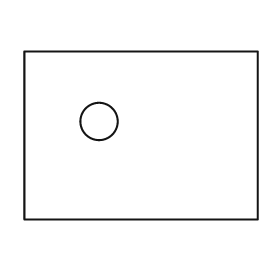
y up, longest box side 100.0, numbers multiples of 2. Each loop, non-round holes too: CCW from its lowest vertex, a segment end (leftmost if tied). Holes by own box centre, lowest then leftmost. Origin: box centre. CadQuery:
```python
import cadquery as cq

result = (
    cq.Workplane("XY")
    .moveTo(-50.0, -36.0)
    .lineTo(50.0, -36.0)
    .lineTo(50.0, 36.0)
    .lineTo(-50.0, 36.0)
    .close()
    .moveTo(-18.0, 6.0)
    .circle(8.0)
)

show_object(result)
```